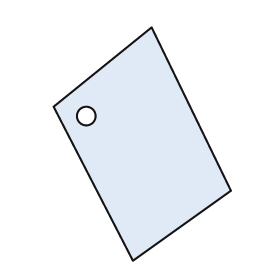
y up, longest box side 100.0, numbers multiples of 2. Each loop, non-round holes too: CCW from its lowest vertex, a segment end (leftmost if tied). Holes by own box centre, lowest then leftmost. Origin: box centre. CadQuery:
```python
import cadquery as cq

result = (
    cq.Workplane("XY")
    .moveTo(-4.0, -50.0)
    .lineTo(38.0, -20.0)
    .lineTo(4.0, 50.0)
    .lineTo(-38.0, 16.0)
    .close()
    .moveTo(-24.0, 12.0)
    .circle(4.0)
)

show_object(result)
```